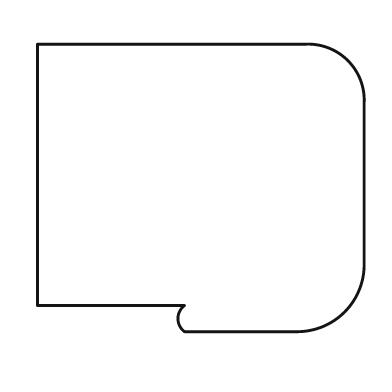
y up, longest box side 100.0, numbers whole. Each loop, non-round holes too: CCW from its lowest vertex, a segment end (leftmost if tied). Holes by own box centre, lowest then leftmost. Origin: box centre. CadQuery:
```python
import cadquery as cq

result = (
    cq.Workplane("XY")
    .moveTo(-5.0, -44.0)
    .lineTo(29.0, -44.0)
    .threePointArc((44.0, -38.0), (50.0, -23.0))
    .lineTo(50.0, 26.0)
    .threePointArc((45.0, 39.0), (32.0, 44.0))
    .lineTo(-50.0, 44.0)
    .lineTo(-50.0, -36.0)
    .lineTo(-5.0, -36.0)
    .threePointArc((-7.0, -40.0), (-5.0, -44.0))
    .close()
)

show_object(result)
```